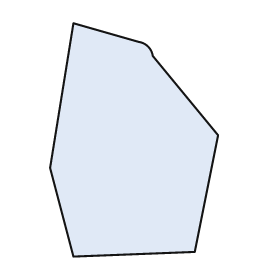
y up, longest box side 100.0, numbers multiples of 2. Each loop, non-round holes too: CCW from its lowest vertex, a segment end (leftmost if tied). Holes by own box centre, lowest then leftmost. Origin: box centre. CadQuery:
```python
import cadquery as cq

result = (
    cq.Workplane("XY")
    .moveTo(-26.0, -50.0)
    .lineTo(26.0, -48.0)
    .lineTo(36.0, 2.0)
    .lineTo(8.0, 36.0)
    .threePointArc((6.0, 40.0), (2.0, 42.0))
    .lineTo(-26.0, 50.0)
    .lineTo(-36.0, -12.0)
    .close()
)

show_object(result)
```